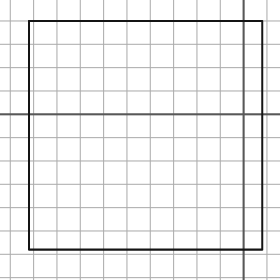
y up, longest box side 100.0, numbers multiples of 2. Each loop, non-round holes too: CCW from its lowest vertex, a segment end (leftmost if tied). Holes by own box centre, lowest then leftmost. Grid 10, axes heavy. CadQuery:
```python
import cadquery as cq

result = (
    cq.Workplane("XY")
    .moveTo(-92.0, -58.0)
    .lineTo(8.0, -58.0)
    .lineTo(8.0, 40.0)
    .lineTo(-92.0, 40.0)
    .close()
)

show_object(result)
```